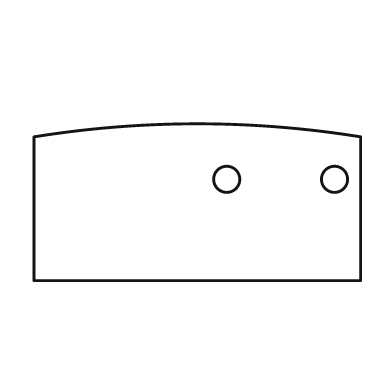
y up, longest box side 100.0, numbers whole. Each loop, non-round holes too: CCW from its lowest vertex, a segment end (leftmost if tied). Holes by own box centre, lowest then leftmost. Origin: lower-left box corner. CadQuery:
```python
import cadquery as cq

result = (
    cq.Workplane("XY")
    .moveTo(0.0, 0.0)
    .lineTo(100.0, 0.0)
    .lineTo(100.0, 44.0)
    .threePointArc((50.0, 48.0), (0.0, 44.0))
    .close()
    .moveTo(59.0, 31.0)
    .circle(4.0)
    .moveTo(92.0, 31.0)
    .circle(4.0)
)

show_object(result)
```